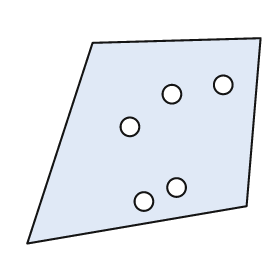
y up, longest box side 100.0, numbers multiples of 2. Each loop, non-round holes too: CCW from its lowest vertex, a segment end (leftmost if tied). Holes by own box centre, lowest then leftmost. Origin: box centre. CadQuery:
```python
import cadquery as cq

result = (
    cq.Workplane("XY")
    .moveTo(-50.0, -44.0)
    .lineTo(44.0, -28.0)
    .lineTo(50.0, 44.0)
    .lineTo(-22.0, 42.0)
    .close()
    .moveTo(0.0, -26.0)
    .circle(4.0)
    .moveTo(14.0, -20.0)
    .circle(4.0)
    .moveTo(-6.0, 6.0)
    .circle(4.0)
    .moveTo(12.0, 20.0)
    .circle(4.0)
    .moveTo(34.0, 24.0)
    .circle(4.0)
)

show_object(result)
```